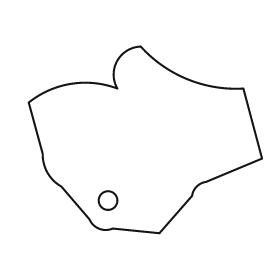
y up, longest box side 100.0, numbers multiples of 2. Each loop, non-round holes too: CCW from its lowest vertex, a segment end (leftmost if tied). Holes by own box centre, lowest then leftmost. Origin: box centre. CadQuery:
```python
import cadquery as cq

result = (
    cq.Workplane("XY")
    .moveTo(6.0, -40.0)
    .lineTo(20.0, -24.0)
    .threePointArc((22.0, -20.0), (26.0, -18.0))
    .lineTo(50.0, -8.0)
    .lineTo(42.0, 22.0)
    .threePointArc((18.0, 26.0), (-2.0, 40.0))
    .threePointArc((-12.0, 34.0), (-12.0, 22.0))
    .threePointArc((-32.0, 24.0), (-50.0, 16.0))
    .lineTo(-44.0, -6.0)
    .threePointArc((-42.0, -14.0), (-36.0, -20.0))
    .lineTo(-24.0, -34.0)
    .threePointArc((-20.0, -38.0), (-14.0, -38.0))
    .close()
    .moveTo(-16.0, -26.0)
    .circle(4.0)
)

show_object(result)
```